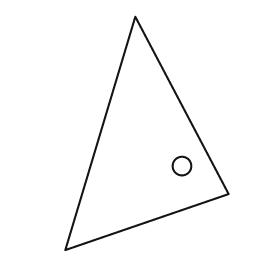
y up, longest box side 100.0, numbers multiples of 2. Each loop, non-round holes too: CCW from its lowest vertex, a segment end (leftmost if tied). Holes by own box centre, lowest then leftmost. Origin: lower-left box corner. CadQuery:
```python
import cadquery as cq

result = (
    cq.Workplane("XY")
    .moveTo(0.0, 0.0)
    .lineTo(70.0, 24.0)
    .lineTo(30.0, 100.0)
    .close()
    .moveTo(50.0, 36.0)
    .circle(4.0)
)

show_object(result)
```